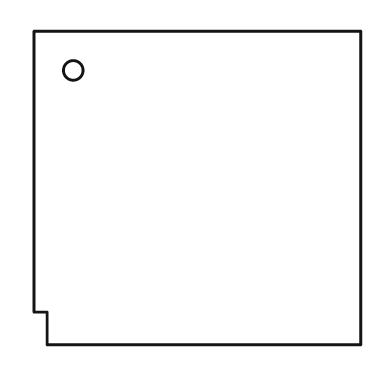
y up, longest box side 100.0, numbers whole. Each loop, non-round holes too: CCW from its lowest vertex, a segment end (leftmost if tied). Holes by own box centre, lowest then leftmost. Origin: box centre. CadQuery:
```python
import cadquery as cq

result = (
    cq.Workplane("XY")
    .moveTo(-46.0, -48.0)
    .lineTo(50.0, -48.0)
    .lineTo(50.0, 48.0)
    .lineTo(-50.0, 48.0)
    .lineTo(-50.0, -38.0)
    .lineTo(-46.0, -38.0)
    .close()
    .moveTo(-38.0, 36.0)
    .circle(3.0)
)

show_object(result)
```